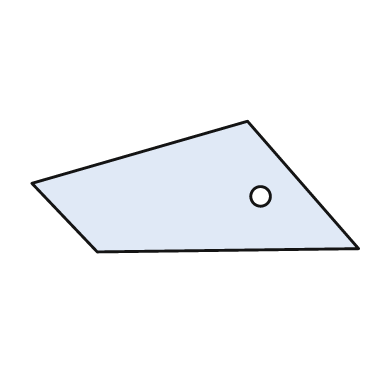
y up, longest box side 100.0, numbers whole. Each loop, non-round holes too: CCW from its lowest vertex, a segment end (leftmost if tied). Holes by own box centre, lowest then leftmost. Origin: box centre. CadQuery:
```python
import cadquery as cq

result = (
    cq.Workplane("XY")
    .moveTo(-30.0, -20.0)
    .lineTo(50.0, -19.0)
    .lineTo(16.0, 20.0)
    .lineTo(-50.0, 1.0)
    .close()
    .moveTo(20.0, -3.0)
    .circle(3.0)
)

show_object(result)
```